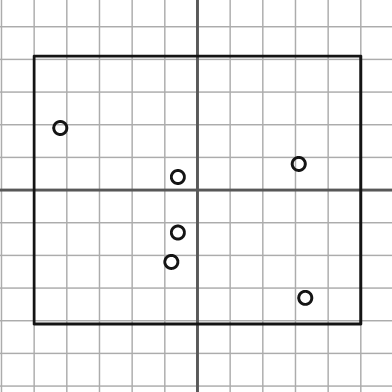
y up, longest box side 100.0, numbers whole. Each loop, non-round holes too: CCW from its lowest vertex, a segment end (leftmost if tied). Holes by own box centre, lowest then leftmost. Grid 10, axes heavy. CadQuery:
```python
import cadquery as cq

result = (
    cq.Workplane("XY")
    .moveTo(-50.0, -41.0)
    .lineTo(50.0, -41.0)
    .lineTo(50.0, 41.0)
    .lineTo(-50.0, 41.0)
    .close()
    .moveTo(33.0, -33.0)
    .circle(2.0)
    .moveTo(-8.0, -22.0)
    .circle(2.0)
    .moveTo(-6.0, -13.0)
    .circle(2.0)
    .moveTo(-6.0, 4.0)
    .circle(2.0)
    .moveTo(31.0, 8.0)
    .circle(2.0)
    .moveTo(-42.0, 19.0)
    .circle(2.0)
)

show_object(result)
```